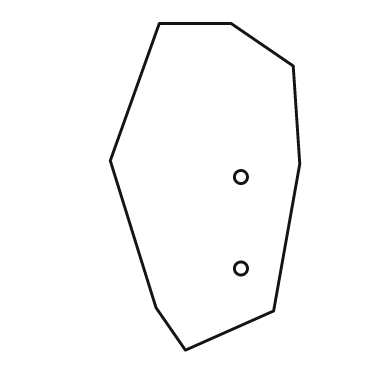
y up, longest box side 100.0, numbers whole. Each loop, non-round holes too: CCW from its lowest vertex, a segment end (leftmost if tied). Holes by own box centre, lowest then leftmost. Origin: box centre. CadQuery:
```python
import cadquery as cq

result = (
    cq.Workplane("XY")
    .moveTo(-6.0, -50.0)
    .lineTo(21.0, -38.0)
    .lineTo(29.0, 7.0)
    .lineTo(27.0, 37.0)
    .lineTo(8.0, 50.0)
    .lineTo(-14.0, 50.0)
    .lineTo(-29.0, 8.0)
    .lineTo(-15.0, -37.0)
    .close()
    .moveTo(11.0, -25.0)
    .circle(2.0)
    .moveTo(11.0, 3.0)
    .circle(2.0)
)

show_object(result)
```